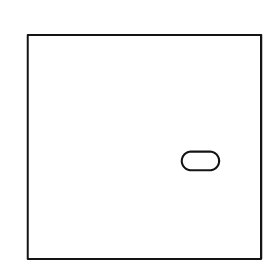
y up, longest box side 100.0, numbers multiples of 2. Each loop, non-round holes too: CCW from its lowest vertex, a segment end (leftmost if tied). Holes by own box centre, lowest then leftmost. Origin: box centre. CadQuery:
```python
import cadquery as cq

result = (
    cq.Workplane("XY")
    .moveTo(-50.0, -48.0)
    .lineTo(50.0, -48.0)
    .lineTo(50.0, 48.0)
    .lineTo(-50.0, 48.0)
    .close()
    .moveTo(20.0, -10.0)
    .lineTo(28.0, -10.0)
    .threePointArc((32.0, -6.0), (28.0, -2.0))
    .lineTo(20.0, -2.0)
    .threePointArc((16.0, -6.0), (20.0, -10.0))
    .close()
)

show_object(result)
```